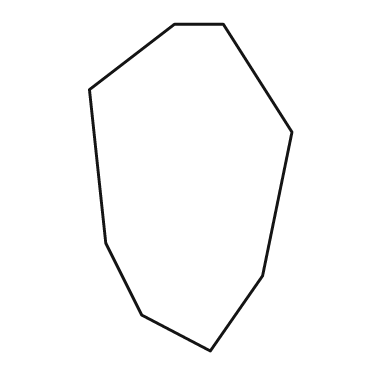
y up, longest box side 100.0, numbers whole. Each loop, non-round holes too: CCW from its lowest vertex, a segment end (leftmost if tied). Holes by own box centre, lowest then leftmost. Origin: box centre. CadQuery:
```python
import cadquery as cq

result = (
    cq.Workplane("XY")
    .moveTo(6.0, -50.0)
    .lineTo(22.0, -27.0)
    .lineTo(31.0, 17.0)
    .lineTo(10.0, 50.0)
    .lineTo(-5.0, 50.0)
    .lineTo(-31.0, 30.0)
    .lineTo(-26.0, -17.0)
    .lineTo(-15.0, -39.0)
    .close()
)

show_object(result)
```